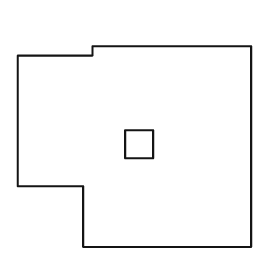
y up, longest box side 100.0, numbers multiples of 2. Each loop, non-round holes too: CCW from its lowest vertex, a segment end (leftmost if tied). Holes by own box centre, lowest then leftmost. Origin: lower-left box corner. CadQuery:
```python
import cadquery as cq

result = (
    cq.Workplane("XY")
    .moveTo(28.0, 0.0)
    .lineTo(100.0, 0.0)
    .lineTo(100.0, 86.0)
    .lineTo(32.0, 86.0)
    .lineTo(32.0, 82.0)
    .lineTo(0.0, 82.0)
    .lineTo(0.0, 26.0)
    .lineTo(28.0, 26.0)
    .close()
    .moveTo(46.0, 38.0)
    .lineTo(58.0, 38.0)
    .lineTo(58.0, 50.0)
    .lineTo(46.0, 50.0)
    .close()
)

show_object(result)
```